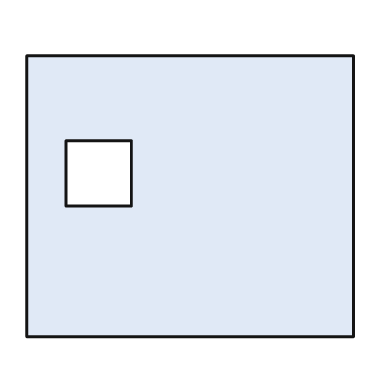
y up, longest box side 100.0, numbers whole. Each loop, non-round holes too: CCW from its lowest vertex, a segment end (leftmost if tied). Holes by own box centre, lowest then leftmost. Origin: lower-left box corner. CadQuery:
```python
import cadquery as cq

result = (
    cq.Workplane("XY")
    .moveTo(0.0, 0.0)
    .lineTo(100.0, 0.0)
    .lineTo(100.0, 86.0)
    .lineTo(0.0, 86.0)
    .close()
    .moveTo(12.0, 40.0)
    .lineTo(32.0, 40.0)
    .lineTo(32.0, 60.0)
    .lineTo(12.0, 60.0)
    .close()
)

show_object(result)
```